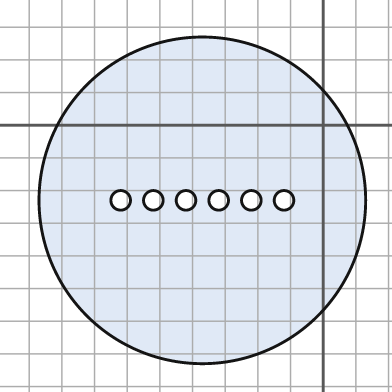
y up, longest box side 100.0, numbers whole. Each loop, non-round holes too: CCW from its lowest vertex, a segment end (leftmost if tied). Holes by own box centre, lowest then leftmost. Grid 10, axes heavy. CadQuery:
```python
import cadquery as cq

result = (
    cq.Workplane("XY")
    .moveTo(-37.0, -23.0)
    .circle(50.0)
    .moveTo(-62.0, -23.0)
    .circle(3.0)
    .moveTo(-52.0, -23.0)
    .circle(3.0)
    .moveTo(-42.0, -23.0)
    .circle(3.0)
    .moveTo(-32.0, -23.0)
    .circle(3.0)
    .moveTo(-22.0, -23.0)
    .circle(3.0)
    .moveTo(-12.0, -23.0)
    .circle(3.0)
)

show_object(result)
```